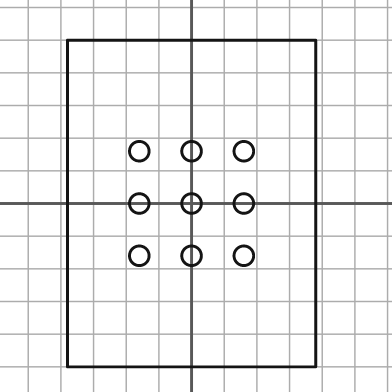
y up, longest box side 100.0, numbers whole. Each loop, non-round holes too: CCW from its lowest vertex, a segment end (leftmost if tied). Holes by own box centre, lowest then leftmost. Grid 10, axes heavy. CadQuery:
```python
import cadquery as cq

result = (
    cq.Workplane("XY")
    .moveTo(-38.0, -50.0)
    .lineTo(38.0, -50.0)
    .lineTo(38.0, 50.0)
    .lineTo(-38.0, 50.0)
    .close()
    .moveTo(-16.0, -16.0)
    .circle(3.0)
    .moveTo(0.0, -16.0)
    .circle(3.0)
    .moveTo(16.0, -16.0)
    .circle(3.0)
    .moveTo(-16.0, 0.0)
    .circle(3.0)
    .moveTo(0.0, 0.0)
    .circle(3.0)
    .moveTo(16.0, 0.0)
    .circle(3.0)
    .moveTo(-16.0, 16.0)
    .circle(3.0)
    .moveTo(0.0, 16.0)
    .circle(3.0)
    .moveTo(16.0, 16.0)
    .circle(3.0)
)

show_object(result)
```